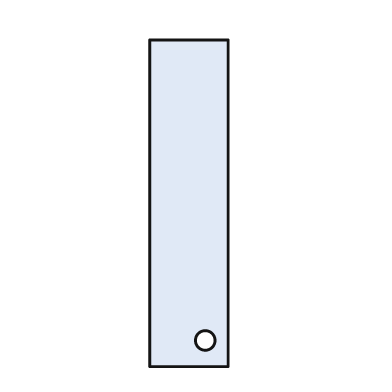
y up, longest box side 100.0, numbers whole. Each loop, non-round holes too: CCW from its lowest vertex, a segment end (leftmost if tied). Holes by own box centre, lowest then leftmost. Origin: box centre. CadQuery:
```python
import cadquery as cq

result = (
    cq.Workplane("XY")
    .moveTo(-12.0, -50.0)
    .lineTo(12.0, -50.0)
    .lineTo(12.0, 50.0)
    .lineTo(-12.0, 50.0)
    .close()
    .moveTo(5.0, -42.0)
    .circle(3.0)
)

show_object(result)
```